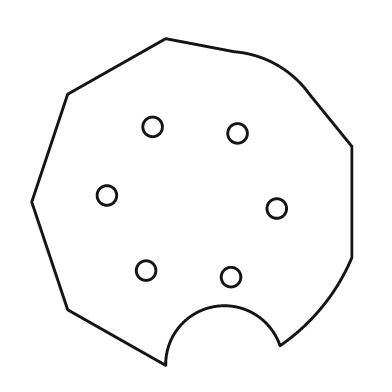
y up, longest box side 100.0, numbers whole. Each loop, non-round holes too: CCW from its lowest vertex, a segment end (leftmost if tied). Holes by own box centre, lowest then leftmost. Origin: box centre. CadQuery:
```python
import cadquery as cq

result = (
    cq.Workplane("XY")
    .moveTo(-8.0, -50.0)
    .threePointArc((7.0, -32.0), (27.0, -44.0))
    .threePointArc((40.0, -32.0), (49.0, -17.0))
    .lineTo(49.0, 17.0)
    .lineTo(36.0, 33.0)
    .threePointArc((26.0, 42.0), (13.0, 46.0))
    .lineTo(-8.0, 50.0)
    .lineTo(-38.0, 33.0)
    .lineTo(-49.0, 0.0)
    .lineTo(-38.0, -33.0)
    .close()
    .moveTo(12.0, -23.0)
    .circle(3.0)
    .moveTo(-14.0, -21.0)
    .circle(3.0)
    .moveTo(26.0, -2.0)
    .circle(3.0)
    .moveTo(-26.0, 2.0)
    .circle(3.0)
    .moveTo(14.0, 21.0)
    .circle(3.0)
    .moveTo(-12.0, 23.0)
    .circle(3.0)
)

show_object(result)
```